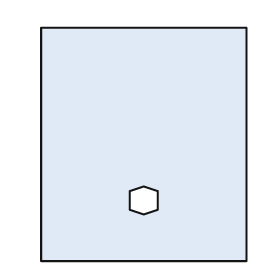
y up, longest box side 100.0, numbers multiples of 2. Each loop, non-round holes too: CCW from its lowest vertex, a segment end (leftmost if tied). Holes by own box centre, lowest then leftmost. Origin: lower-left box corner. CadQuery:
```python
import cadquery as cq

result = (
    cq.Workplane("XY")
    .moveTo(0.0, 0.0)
    .lineTo(88.0, 0.0)
    .lineTo(88.0, 100.0)
    .lineTo(0.0, 100.0)
    .close()
    .moveTo(44.0, 20.0)
    .lineTo(50.0, 22.0)
    .lineTo(50.0, 30.0)
    .lineTo(44.0, 32.0)
    .lineTo(38.0, 30.0)
    .lineTo(38.0, 22.0)
    .close()
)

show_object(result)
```